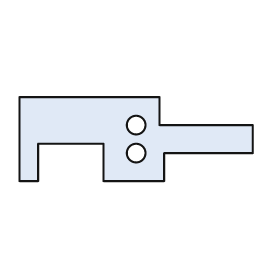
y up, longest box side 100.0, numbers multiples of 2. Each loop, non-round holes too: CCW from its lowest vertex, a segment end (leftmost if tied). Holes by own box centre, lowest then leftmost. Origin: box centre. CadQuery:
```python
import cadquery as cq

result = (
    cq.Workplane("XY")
    .moveTo(-50.0, -18.0)
    .lineTo(-42.0, -18.0)
    .lineTo(-42.0, -2.0)
    .lineTo(-14.0, -2.0)
    .lineTo(-14.0, -18.0)
    .lineTo(12.0, -18.0)
    .lineTo(12.0, -6.0)
    .lineTo(50.0, -6.0)
    .lineTo(50.0, 6.0)
    .lineTo(10.0, 6.0)
    .lineTo(10.0, 18.0)
    .lineTo(-50.0, 18.0)
    .close()
    .moveTo(0.0, -6.0)
    .circle(4.0)
    .moveTo(0.0, 6.0)
    .circle(4.0)
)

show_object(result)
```